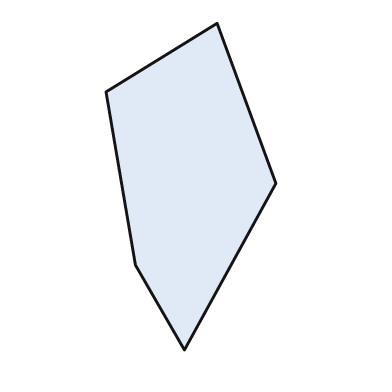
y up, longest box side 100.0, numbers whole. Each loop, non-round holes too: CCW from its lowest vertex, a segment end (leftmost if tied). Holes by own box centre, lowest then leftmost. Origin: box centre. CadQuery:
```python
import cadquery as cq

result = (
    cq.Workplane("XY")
    .moveTo(-2.0, -50.0)
    .lineTo(26.0, 1.0)
    .lineTo(8.0, 50.0)
    .lineTo(-26.0, 29.0)
    .lineTo(-17.0, -24.0)
    .close()
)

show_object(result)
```